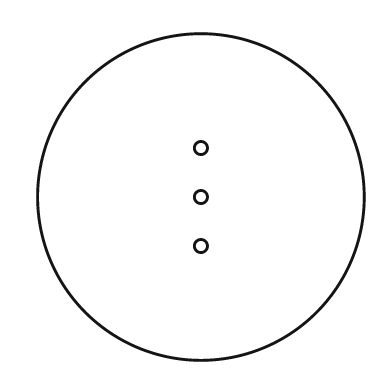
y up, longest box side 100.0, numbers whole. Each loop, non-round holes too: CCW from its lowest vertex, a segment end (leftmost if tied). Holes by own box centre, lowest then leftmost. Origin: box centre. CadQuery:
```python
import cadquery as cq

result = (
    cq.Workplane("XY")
    .moveTo(0.0, 0.0)
    .circle(50.0)
    .moveTo(0.0, -15.0)
    .circle(2.0)
    .moveTo(0.0, 0.0)
    .circle(2.0)
    .moveTo(0.0, 15.0)
    .circle(2.0)
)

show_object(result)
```